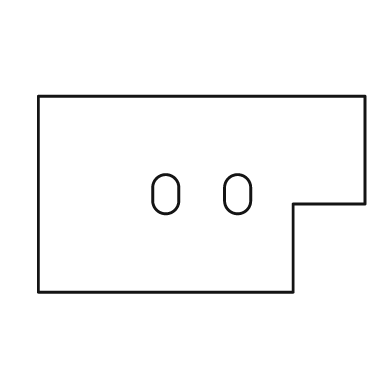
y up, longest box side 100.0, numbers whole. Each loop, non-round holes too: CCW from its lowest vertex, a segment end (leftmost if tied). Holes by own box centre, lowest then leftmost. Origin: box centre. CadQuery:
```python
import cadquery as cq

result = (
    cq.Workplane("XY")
    .moveTo(-50.0, -30.0)
    .lineTo(28.0, -30.0)
    .lineTo(28.0, -3.0)
    .lineTo(50.0, -3.0)
    .lineTo(50.0, 30.0)
    .lineTo(-50.0, 30.0)
    .close()
    .moveTo(-15.0, -2.0)
    .threePointArc((-11.0, -6.0), (-7.0, -2.0))
    .lineTo(-7.0, 2.0)
    .threePointArc((-11.0, 6.0), (-15.0, 2.0))
    .close()
    .moveTo(7.0, -2.0)
    .threePointArc((11.0, -6.0), (15.0, -2.0))
    .lineTo(15.0, 2.0)
    .threePointArc((11.0, 6.0), (7.0, 2.0))
    .close()
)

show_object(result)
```